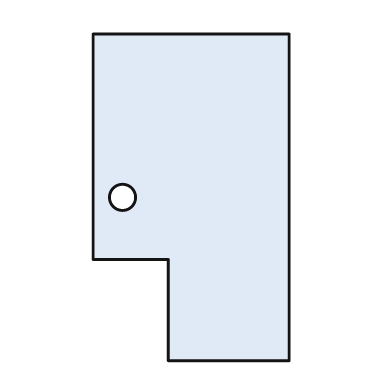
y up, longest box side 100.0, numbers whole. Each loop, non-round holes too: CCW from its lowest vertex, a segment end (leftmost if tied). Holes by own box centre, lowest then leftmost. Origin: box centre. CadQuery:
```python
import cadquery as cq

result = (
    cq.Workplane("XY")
    .moveTo(-7.0, -50.0)
    .lineTo(30.0, -50.0)
    .lineTo(30.0, 50.0)
    .lineTo(-30.0, 50.0)
    .lineTo(-30.0, -19.0)
    .lineTo(-7.0, -19.0)
    .close()
    .moveTo(-21.0, 0.0)
    .circle(4.0)
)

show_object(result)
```